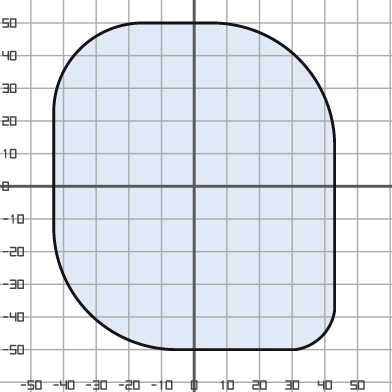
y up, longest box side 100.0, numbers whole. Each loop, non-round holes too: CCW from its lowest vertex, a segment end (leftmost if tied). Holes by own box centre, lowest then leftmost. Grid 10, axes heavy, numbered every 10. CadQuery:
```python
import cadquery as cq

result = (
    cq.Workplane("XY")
    .moveTo(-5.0, -50.0)
    .lineTo(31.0, -50.0)
    .threePointArc((39.0, -46.0), (43.0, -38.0))
    .lineTo(43.0, 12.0)
    .threePointArc((32.0, 39.0), (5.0, 50.0))
    .lineTo(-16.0, 50.0)
    .threePointArc((-35.0, 42.0), (-43.0, 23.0))
    .lineTo(-43.0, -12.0)
    .threePointArc((-32.0, -39.0), (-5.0, -50.0))
    .close()
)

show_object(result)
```